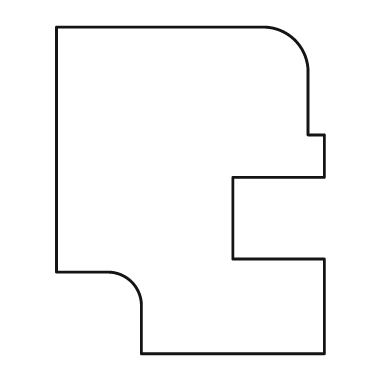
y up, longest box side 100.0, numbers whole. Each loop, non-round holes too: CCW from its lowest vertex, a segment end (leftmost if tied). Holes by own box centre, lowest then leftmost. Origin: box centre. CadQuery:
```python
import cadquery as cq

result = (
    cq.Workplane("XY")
    .moveTo(-15.0, -50.0)
    .lineTo(41.0, -50.0)
    .lineTo(41.0, -21.0)
    .lineTo(13.0, -21.0)
    .lineTo(13.0, 4.0)
    .lineTo(41.0, 4.0)
    .lineTo(41.0, 17.0)
    .lineTo(36.0, 17.0)
    .lineTo(36.0, 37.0)
    .threePointArc((32.0, 46.0), (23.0, 50.0))
    .lineTo(-41.0, 50.0)
    .lineTo(-41.0, -25.0)
    .lineTo(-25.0, -25.0)
    .threePointArc((-18.0, -28.0), (-15.0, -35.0))
    .close()
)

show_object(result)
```